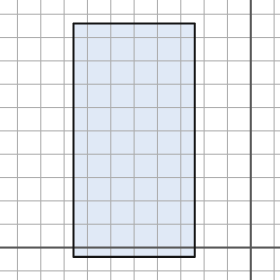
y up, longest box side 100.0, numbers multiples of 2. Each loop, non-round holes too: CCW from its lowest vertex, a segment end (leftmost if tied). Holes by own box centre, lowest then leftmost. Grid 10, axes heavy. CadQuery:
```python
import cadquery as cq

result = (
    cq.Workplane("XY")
    .moveTo(-76.0, -4.0)
    .lineTo(-24.0, -4.0)
    .lineTo(-24.0, 96.0)
    .lineTo(-76.0, 96.0)
    .close()
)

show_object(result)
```